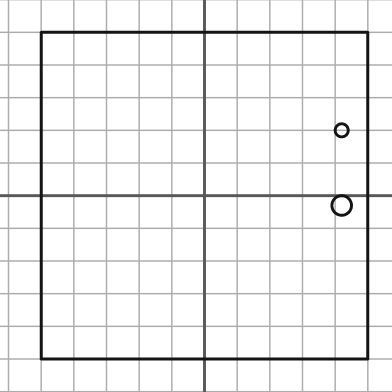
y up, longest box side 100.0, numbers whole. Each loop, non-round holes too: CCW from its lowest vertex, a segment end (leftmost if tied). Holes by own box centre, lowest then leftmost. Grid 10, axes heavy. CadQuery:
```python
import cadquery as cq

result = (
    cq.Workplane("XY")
    .moveTo(-50.0, -50.0)
    .lineTo(50.0, -50.0)
    .lineTo(50.0, 50.0)
    .lineTo(-50.0, 50.0)
    .close()
    .moveTo(42.0, -3.0)
    .circle(3.0)
    .moveTo(42.0, 20.0)
    .circle(2.0)
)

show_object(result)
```